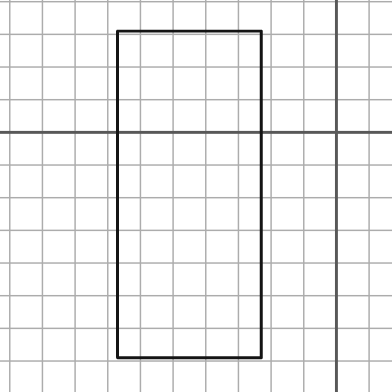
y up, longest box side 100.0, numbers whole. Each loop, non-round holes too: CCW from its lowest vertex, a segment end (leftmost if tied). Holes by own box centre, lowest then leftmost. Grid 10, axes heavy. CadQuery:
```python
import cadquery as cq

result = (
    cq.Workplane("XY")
    .moveTo(-67.0, -69.0)
    .lineTo(-23.0, -69.0)
    .lineTo(-23.0, 31.0)
    .lineTo(-67.0, 31.0)
    .close()
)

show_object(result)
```